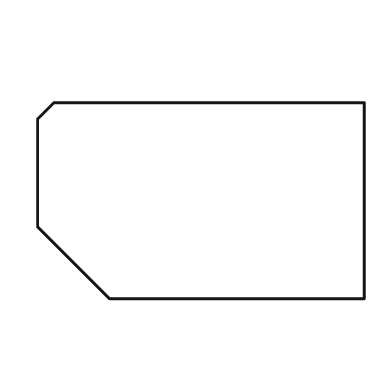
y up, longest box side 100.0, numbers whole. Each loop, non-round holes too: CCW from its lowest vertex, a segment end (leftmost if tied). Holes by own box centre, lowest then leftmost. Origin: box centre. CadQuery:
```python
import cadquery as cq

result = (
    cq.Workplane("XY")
    .moveTo(-28.0, -30.0)
    .lineTo(50.0, -30.0)
    .lineTo(50.0, 30.0)
    .lineTo(-45.0, 30.0)
    .lineTo(-50.0, 25.0)
    .lineTo(-50.0, -8.0)
    .close()
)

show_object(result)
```